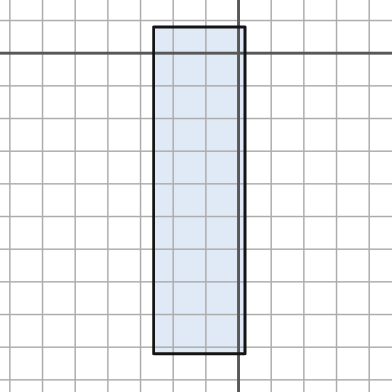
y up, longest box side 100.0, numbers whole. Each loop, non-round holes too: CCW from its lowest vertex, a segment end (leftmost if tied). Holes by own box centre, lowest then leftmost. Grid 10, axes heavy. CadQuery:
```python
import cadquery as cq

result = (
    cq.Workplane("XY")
    .moveTo(-26.0, -92.0)
    .lineTo(2.0, -92.0)
    .lineTo(2.0, 8.0)
    .lineTo(-26.0, 8.0)
    .close()
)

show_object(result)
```